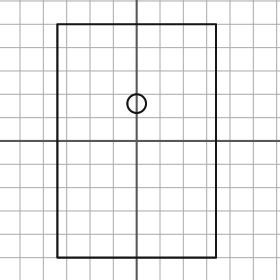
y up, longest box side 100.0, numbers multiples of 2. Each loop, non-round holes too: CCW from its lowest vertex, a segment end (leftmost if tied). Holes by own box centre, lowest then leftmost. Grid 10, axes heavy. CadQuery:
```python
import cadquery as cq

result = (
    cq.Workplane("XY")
    .moveTo(-34.0, -50.0)
    .lineTo(34.0, -50.0)
    .lineTo(34.0, 50.0)
    .lineTo(-34.0, 50.0)
    .close()
    .moveTo(0.0, 16.0)
    .circle(4.0)
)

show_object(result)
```